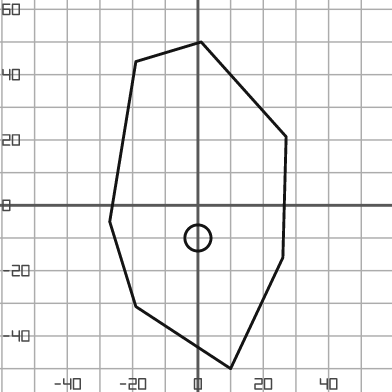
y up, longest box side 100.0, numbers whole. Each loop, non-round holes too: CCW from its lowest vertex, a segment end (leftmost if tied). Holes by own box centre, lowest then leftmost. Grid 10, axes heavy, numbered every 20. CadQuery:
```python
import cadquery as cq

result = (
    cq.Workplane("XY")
    .moveTo(10.0, -50.0)
    .lineTo(26.0, -16.0)
    .lineTo(27.0, 21.0)
    .lineTo(1.0, 50.0)
    .lineTo(-19.0, 44.0)
    .lineTo(-27.0, -5.0)
    .lineTo(-19.0, -31.0)
    .close()
    .moveTo(0.0, -10.0)
    .circle(4.0)
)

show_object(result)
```